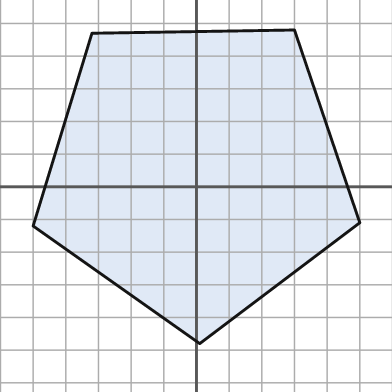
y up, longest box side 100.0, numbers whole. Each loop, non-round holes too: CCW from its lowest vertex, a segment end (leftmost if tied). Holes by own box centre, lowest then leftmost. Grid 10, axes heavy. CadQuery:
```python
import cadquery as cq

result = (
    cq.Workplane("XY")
    .moveTo(1.0, -48.0)
    .lineTo(50.0, -11.0)
    .lineTo(30.0, 48.0)
    .lineTo(-32.0, 47.0)
    .lineTo(-50.0, -12.0)
    .close()
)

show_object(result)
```